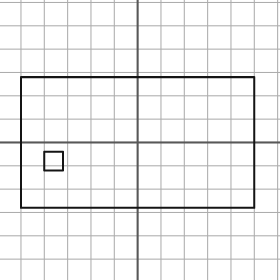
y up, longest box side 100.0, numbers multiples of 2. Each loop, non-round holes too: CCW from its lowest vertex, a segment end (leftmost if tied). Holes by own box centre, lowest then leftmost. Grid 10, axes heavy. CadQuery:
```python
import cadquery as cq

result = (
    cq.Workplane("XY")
    .moveTo(-50.0, -28.0)
    .lineTo(50.0, -28.0)
    .lineTo(50.0, 28.0)
    .lineTo(-50.0, 28.0)
    .close()
    .moveTo(-40.0, -12.0)
    .lineTo(-32.0, -12.0)
    .lineTo(-32.0, -4.0)
    .lineTo(-40.0, -4.0)
    .close()
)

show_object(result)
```